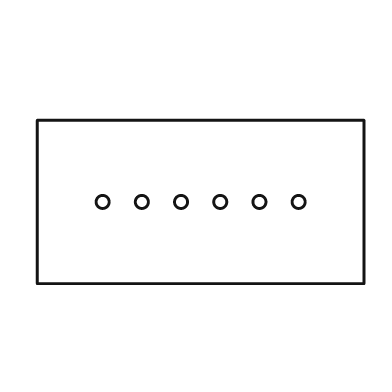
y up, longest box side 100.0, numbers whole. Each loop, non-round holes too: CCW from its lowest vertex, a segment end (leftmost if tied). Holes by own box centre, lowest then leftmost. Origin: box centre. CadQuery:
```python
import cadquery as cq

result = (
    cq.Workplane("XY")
    .moveTo(-50.0, -25.0)
    .lineTo(50.0, -25.0)
    .lineTo(50.0, 25.0)
    .lineTo(-50.0, 25.0)
    .close()
    .moveTo(-30.0, 0.0)
    .circle(2.0)
    .moveTo(-18.0, 0.0)
    .circle(2.0)
    .moveTo(-6.0, 0.0)
    .circle(2.0)
    .moveTo(6.0, 0.0)
    .circle(2.0)
    .moveTo(18.0, 0.0)
    .circle(2.0)
    .moveTo(30.0, 0.0)
    .circle(2.0)
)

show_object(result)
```